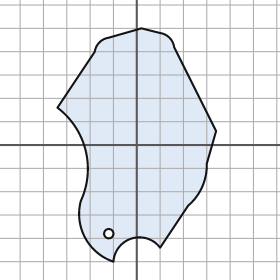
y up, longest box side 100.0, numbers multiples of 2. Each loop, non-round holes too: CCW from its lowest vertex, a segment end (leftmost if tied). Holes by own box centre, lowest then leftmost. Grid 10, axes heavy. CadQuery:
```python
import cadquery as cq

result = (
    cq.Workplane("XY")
    .moveTo(-10.0, -50.0)
    .threePointArc((-2.0, -40.0), (10.0, -44.0))
    .lineTo(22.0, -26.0)
    .threePointArc((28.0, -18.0), (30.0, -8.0))
    .lineTo(34.0, 6.0)
    .lineTo(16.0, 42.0)
    .threePointArc((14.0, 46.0), (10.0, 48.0))
    .lineTo(2.0, 50.0)
    .lineTo(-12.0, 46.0)
    .threePointArc((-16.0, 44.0), (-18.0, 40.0))
    .lineTo(-34.0, 16.0)
    .threePointArc((-22.0, -2.0), (-24.0, -24.0))
    .threePointArc((-22.0, -40.0), (-10.0, -50.0))
    .close()
    .moveTo(-12.0, -38.0)
    .circle(2.0)
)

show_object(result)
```